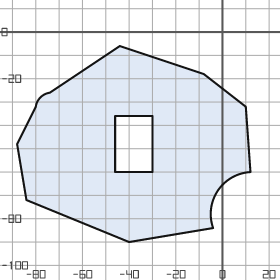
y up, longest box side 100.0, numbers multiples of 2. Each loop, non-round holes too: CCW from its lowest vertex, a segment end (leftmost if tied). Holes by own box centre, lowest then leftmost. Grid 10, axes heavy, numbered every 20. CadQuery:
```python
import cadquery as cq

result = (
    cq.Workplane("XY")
    .moveTo(-40.0, -90.0)
    .lineTo(-4.0, -84.0)
    .threePointArc((-2.0, -68.0), (12.0, -60.0))
    .lineTo(10.0, -32.0)
    .lineTo(-8.0, -18.0)
    .lineTo(-44.0, -6.0)
    .lineTo(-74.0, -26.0)
    .threePointArc((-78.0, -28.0), (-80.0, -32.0))
    .lineTo(-88.0, -48.0)
    .lineTo(-84.0, -72.0)
    .close()
    .moveTo(-46.0, -60.0)
    .lineTo(-30.0, -60.0)
    .lineTo(-30.0, -36.0)
    .lineTo(-46.0, -36.0)
    .close()
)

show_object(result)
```